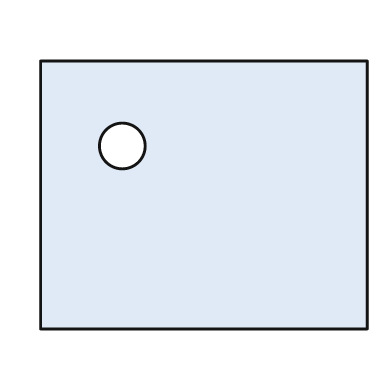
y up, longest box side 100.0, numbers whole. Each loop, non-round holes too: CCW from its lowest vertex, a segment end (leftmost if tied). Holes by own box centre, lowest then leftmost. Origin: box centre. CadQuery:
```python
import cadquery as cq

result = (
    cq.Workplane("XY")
    .moveTo(-50.0, -41.0)
    .lineTo(50.0, -41.0)
    .lineTo(50.0, 41.0)
    .lineTo(-50.0, 41.0)
    .close()
    .moveTo(-25.0, 15.0)
    .circle(7.0)
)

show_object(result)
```